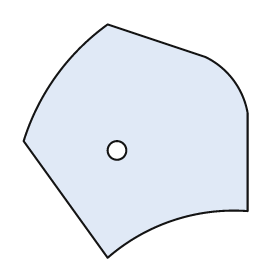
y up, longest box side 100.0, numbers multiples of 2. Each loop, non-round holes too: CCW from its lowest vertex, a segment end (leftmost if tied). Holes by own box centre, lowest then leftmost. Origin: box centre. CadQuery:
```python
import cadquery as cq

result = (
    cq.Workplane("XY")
    .moveTo(-12.0, -50.0)
    .threePointArc((16.0, -34.0), (48.0, -30.0))
    .lineTo(48.0, 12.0)
    .threePointArc((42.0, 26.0), (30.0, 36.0))
    .lineTo(-12.0, 50.0)
    .threePointArc((-34.0, 28.0), (-48.0, 0.0))
    .close()
    .moveTo(-8.0, -4.0)
    .circle(4.0)
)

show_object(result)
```